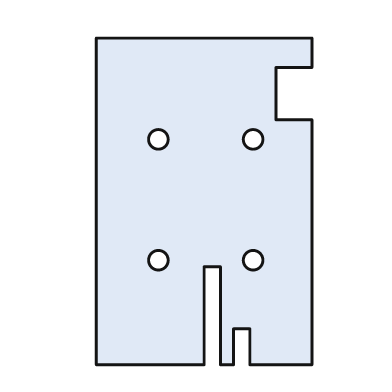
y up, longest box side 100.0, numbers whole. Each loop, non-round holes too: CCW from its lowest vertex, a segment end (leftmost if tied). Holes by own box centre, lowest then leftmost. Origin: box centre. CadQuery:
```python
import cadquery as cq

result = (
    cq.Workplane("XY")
    .moveTo(-33.0, -50.0)
    .lineTo(0.0, -50.0)
    .lineTo(0.0, -20.0)
    .lineTo(5.0, -20.0)
    .lineTo(5.0, -50.0)
    .lineTo(9.0, -50.0)
    .lineTo(9.0, -39.0)
    .lineTo(14.0, -39.0)
    .lineTo(14.0, -50.0)
    .lineTo(33.0, -50.0)
    .lineTo(33.0, 25.0)
    .lineTo(22.0, 25.0)
    .lineTo(22.0, 41.0)
    .lineTo(33.0, 41.0)
    .lineTo(33.0, 50.0)
    .lineTo(-33.0, 50.0)
    .close()
    .moveTo(-14.0, -18.0)
    .circle(3.0)
    .moveTo(15.0, -18.0)
    .circle(3.0)
    .moveTo(-14.0, 19.0)
    .circle(3.0)
    .moveTo(15.0, 19.0)
    .circle(3.0)
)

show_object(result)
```